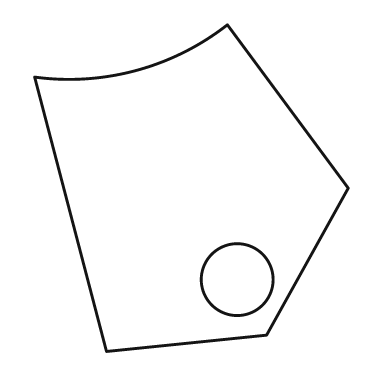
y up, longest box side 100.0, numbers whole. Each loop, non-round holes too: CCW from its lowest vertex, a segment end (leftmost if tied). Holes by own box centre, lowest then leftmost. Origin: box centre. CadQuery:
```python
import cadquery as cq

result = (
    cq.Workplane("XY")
    .moveTo(-26.0, -50.0)
    .lineTo(23.0, -45.0)
    .lineTo(48.0, 0.0)
    .lineTo(11.0, 50.0)
    .threePointArc((-17.0, 36.0), (-48.0, 34.0))
    .close()
    .moveTo(14.0, -28.0)
    .circle(11.0)
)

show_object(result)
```